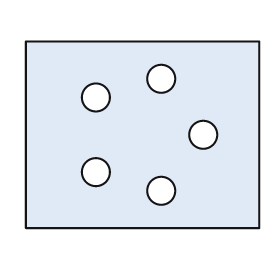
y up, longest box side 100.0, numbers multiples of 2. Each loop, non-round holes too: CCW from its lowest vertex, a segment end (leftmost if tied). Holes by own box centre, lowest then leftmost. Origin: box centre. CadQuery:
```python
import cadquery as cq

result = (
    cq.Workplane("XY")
    .moveTo(-50.0, -40.0)
    .lineTo(50.0, -40.0)
    .lineTo(50.0, 40.0)
    .lineTo(-50.0, 40.0)
    .close()
    .moveTo(8.0, -24.0)
    .circle(6.0)
    .moveTo(-20.0, -16.0)
    .circle(6.0)
    .moveTo(26.0, 0.0)
    .circle(6.0)
    .moveTo(-20.0, 16.0)
    .circle(6.0)
    .moveTo(8.0, 24.0)
    .circle(6.0)
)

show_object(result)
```